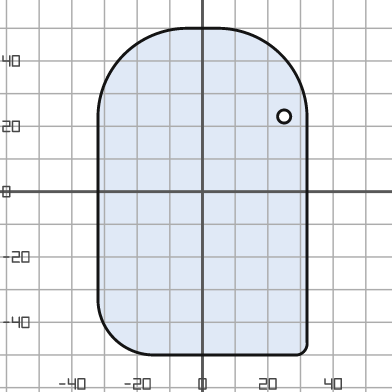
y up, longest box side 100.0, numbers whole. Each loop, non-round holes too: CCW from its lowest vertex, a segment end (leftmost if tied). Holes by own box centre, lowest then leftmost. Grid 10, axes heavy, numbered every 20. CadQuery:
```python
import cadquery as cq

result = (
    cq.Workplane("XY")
    .moveTo(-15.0, -50.0)
    .lineTo(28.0, -50.0)
    .threePointArc((31.0, -49.0), (32.0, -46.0))
    .lineTo(32.0, 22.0)
    .threePointArc((24.0, 42.0), (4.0, 50.0))
    .lineTo(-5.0, 50.0)
    .threePointArc((-24.0, 42.0), (-32.0, 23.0))
    .lineTo(-32.0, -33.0)
    .threePointArc((-27.0, -45.0), (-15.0, -50.0))
    .close()
    .moveTo(25.0, 23.0)
    .circle(2.0)
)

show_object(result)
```